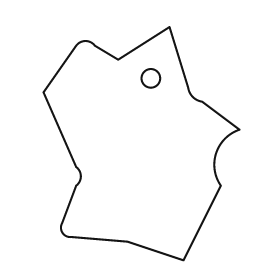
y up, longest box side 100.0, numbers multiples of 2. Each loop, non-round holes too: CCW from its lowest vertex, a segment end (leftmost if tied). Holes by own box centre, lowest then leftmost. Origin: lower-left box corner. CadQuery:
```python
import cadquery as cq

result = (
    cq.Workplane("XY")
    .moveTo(60.0, 0.0)
    .lineTo(76.0, 32.0)
    .threePointArc((74.0, 46.0), (84.0, 56.0))
    .lineTo(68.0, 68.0)
    .threePointArc((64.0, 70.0), (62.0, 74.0))
    .lineTo(54.0, 100.0)
    .lineTo(32.0, 86.0)
    .lineTo(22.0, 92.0)
    .threePointArc((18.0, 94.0), (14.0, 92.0))
    .lineTo(0.0, 72.0)
    .lineTo(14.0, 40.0)
    .threePointArc((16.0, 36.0), (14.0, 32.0))
    .lineTo(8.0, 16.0)
    .threePointArc((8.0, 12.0), (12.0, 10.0))
    .lineTo(36.0, 8.0)
    .close()
    .moveTo(46.0, 78.0)
    .circle(4.0)
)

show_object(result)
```